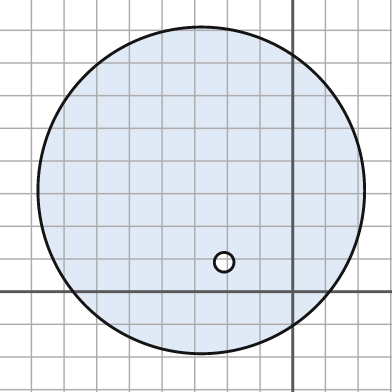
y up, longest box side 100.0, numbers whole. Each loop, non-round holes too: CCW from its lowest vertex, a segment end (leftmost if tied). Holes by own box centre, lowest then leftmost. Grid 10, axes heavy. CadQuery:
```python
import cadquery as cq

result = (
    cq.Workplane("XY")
    .moveTo(-28.0, 31.0)
    .circle(50.0)
    .moveTo(-21.0, 9.0)
    .circle(3.0)
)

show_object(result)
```